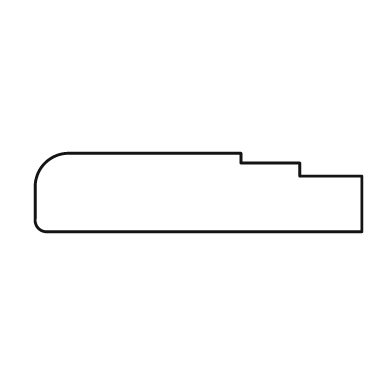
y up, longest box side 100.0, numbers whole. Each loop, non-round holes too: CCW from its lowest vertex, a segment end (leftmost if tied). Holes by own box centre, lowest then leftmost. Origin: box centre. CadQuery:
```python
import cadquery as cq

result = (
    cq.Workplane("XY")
    .moveTo(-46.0, -12.0)
    .lineTo(50.0, -12.0)
    .lineTo(50.0, 5.0)
    .lineTo(31.0, 5.0)
    .lineTo(31.0, 9.0)
    .lineTo(13.0, 9.0)
    .lineTo(13.0, 12.0)
    .lineTo(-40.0, 12.0)
    .threePointArc((-47.0, 9.0), (-50.0, 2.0))
    .lineTo(-50.0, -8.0)
    .threePointArc((-49.0, -11.0), (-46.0, -12.0))
    .close()
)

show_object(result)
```